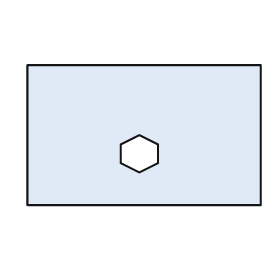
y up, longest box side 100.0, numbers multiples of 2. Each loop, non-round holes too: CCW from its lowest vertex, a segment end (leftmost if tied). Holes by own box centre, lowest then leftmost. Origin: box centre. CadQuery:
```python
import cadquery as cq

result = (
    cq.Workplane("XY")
    .moveTo(-50.0, -30.0)
    .lineTo(50.0, -30.0)
    .lineTo(50.0, 30.0)
    .lineTo(-50.0, 30.0)
    .close()
    .moveTo(-2.0, -16.0)
    .lineTo(6.0, -12.0)
    .lineTo(6.0, -4.0)
    .lineTo(-2.0, 0.0)
    .lineTo(-10.0, -4.0)
    .lineTo(-10.0, -12.0)
    .close()
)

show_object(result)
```